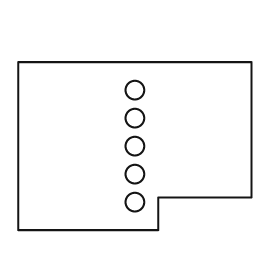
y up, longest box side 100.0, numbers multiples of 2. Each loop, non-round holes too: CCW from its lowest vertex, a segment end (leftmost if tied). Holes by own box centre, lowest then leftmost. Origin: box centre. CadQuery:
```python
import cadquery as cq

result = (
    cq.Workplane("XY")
    .moveTo(-50.0, -36.0)
    .lineTo(10.0, -36.0)
    .lineTo(10.0, -22.0)
    .lineTo(50.0, -22.0)
    .lineTo(50.0, 36.0)
    .lineTo(-50.0, 36.0)
    .close()
    .moveTo(0.0, -24.0)
    .circle(4.0)
    .moveTo(0.0, -12.0)
    .circle(4.0)
    .moveTo(0.0, 0.0)
    .circle(4.0)
    .moveTo(0.0, 12.0)
    .circle(4.0)
    .moveTo(0.0, 24.0)
    .circle(4.0)
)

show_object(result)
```